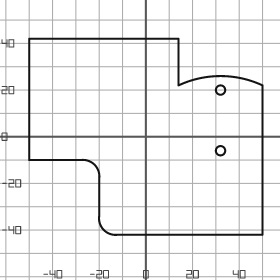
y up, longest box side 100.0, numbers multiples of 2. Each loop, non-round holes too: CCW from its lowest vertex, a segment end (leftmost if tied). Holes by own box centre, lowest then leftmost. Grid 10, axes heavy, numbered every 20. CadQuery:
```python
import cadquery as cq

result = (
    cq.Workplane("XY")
    .moveTo(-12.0, -42.0)
    .lineTo(50.0, -42.0)
    .lineTo(50.0, 22.0)
    .threePointArc((32.0, 26.0), (14.0, 22.0))
    .lineTo(14.0, 42.0)
    .lineTo(-50.0, 42.0)
    .lineTo(-50.0, -10.0)
    .lineTo(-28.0, -10.0)
    .threePointArc((-22.0, -12.0), (-20.0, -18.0))
    .lineTo(-20.0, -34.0)
    .threePointArc((-18.0, -40.0), (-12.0, -42.0))
    .close()
    .moveTo(32.0, -6.0)
    .circle(2.0)
    .moveTo(32.0, 20.0)
    .circle(2.0)
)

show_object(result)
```